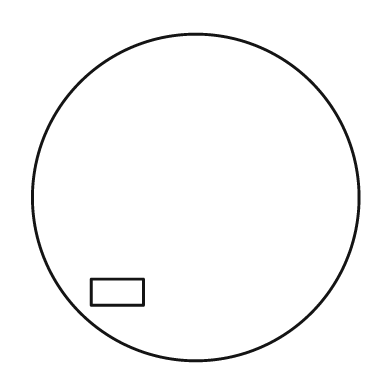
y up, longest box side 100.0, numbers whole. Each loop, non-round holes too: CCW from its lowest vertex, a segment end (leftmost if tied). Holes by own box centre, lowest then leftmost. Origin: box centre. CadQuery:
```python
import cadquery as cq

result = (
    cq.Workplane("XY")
    .moveTo(0.0, 0.0)
    .circle(50.0)
    .moveTo(-32.0, -33.0)
    .lineTo(-16.0, -33.0)
    .lineTo(-16.0, -25.0)
    .lineTo(-32.0, -25.0)
    .close()
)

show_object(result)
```